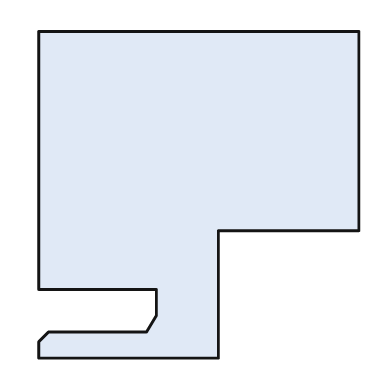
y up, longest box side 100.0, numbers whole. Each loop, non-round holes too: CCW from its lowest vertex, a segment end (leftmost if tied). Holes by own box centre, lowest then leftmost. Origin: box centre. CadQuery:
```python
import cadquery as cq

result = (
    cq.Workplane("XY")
    .moveTo(-49.0, -50.0)
    .lineTo(6.0, -50.0)
    .lineTo(6.0, -11.0)
    .lineTo(49.0, -11.0)
    .lineTo(49.0, 50.0)
    .lineTo(-49.0, 50.0)
    .lineTo(-49.0, -29.0)
    .lineTo(-13.0, -29.0)
    .lineTo(-13.0, -37.0)
    .lineTo(-16.0, -42.0)
    .lineTo(-46.0, -42.0)
    .lineTo(-49.0, -45.0)
    .close()
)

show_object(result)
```